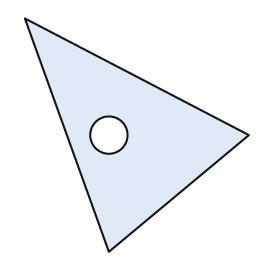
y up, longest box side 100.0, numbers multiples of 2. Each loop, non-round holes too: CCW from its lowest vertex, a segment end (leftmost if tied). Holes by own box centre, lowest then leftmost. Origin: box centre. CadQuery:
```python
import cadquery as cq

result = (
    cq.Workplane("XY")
    .moveTo(-12.0, -50.0)
    .lineTo(48.0, 0.0)
    .lineTo(-48.0, 50.0)
    .close()
    .moveTo(-12.0, 0.0)
    .circle(8.0)
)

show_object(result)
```